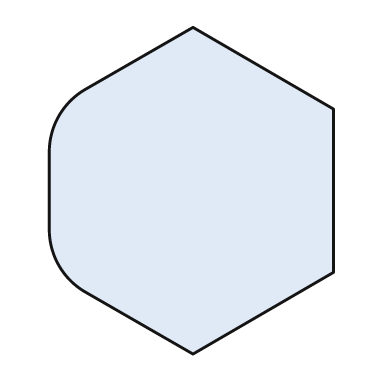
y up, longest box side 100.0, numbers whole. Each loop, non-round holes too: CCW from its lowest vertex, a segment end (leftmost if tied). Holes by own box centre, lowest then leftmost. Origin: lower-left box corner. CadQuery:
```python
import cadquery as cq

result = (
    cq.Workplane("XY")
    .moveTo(44.0, 0.0)
    .lineTo(87.0, 25.0)
    .lineTo(87.0, 75.0)
    .lineTo(44.0, 100.0)
    .lineTo(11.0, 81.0)
    .threePointArc((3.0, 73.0), (0.0, 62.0))
    .lineTo(0.0, 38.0)
    .threePointArc((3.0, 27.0), (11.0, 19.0))
    .close()
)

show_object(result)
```